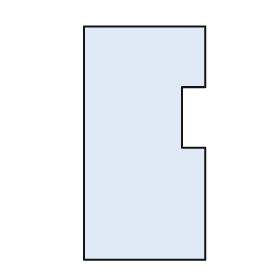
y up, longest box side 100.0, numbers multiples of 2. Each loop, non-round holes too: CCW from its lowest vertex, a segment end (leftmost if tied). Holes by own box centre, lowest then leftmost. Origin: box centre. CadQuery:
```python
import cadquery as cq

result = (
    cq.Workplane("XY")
    .moveTo(-26.0, -50.0)
    .lineTo(26.0, -50.0)
    .lineTo(26.0, -2.0)
    .lineTo(16.0, -2.0)
    .lineTo(16.0, 24.0)
    .lineTo(26.0, 24.0)
    .lineTo(26.0, 50.0)
    .lineTo(-26.0, 50.0)
    .close()
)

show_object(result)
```